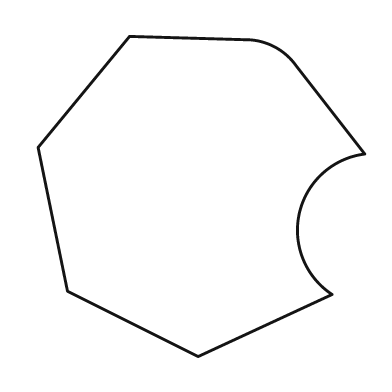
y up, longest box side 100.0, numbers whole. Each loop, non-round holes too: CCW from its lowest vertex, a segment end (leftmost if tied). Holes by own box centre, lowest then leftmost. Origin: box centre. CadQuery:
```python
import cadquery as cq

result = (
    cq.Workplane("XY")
    .moveTo(-1.0, -49.0)
    .lineTo(40.0, -30.0)
    .threePointArc((30.0, -5.0), (50.0, 13.0))
    .lineTo(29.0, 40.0)
    .threePointArc((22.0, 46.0), (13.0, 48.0))
    .lineTo(-22.0, 49.0)
    .lineTo(-50.0, 15.0)
    .lineTo(-41.0, -29.0)
    .close()
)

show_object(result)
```